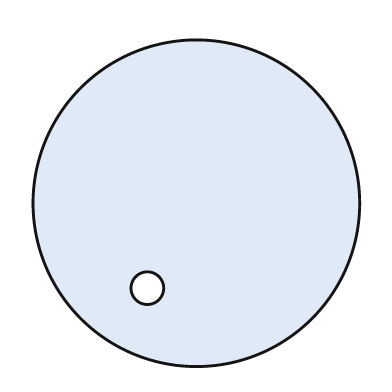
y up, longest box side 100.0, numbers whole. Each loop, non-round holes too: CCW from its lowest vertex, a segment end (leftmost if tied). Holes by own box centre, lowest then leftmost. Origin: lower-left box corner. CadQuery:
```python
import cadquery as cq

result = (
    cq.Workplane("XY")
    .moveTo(50.0, 50.0)
    .circle(50.0)
    .moveTo(35.0, 24.0)
    .circle(5.0)
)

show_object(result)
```